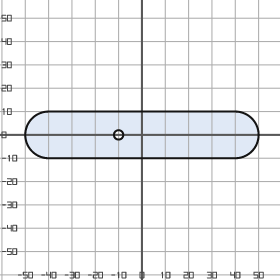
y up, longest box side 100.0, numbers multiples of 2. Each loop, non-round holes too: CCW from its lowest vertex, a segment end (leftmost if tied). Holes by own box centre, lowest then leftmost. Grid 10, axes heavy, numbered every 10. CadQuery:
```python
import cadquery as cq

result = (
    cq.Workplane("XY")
    .moveTo(-40.0, -10.0)
    .lineTo(40.0, -10.0)
    .threePointArc((50.0, 0.0), (40.0, 10.0))
    .lineTo(-40.0, 10.0)
    .threePointArc((-50.0, 0.0), (-40.0, -10.0))
    .close()
    .moveTo(-10.0, 0.0)
    .circle(2.0)
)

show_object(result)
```